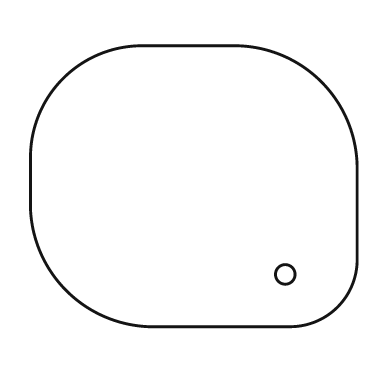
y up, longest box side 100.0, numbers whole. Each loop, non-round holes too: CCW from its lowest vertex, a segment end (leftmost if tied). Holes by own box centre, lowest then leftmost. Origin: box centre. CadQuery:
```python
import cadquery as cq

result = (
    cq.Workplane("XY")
    .moveTo(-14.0, -43.0)
    .lineTo(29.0, -43.0)
    .threePointArc((44.0, -37.0), (50.0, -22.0))
    .lineTo(50.0, 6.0)
    .threePointArc((39.0, 32.0), (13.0, 43.0))
    .lineTo(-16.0, 43.0)
    .threePointArc((-40.0, 33.0), (-50.0, 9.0))
    .lineTo(-50.0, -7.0)
    .threePointArc((-39.0, -32.0), (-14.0, -43.0))
    .close()
    .moveTo(28.0, -27.0)
    .circle(3.0)
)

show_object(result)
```